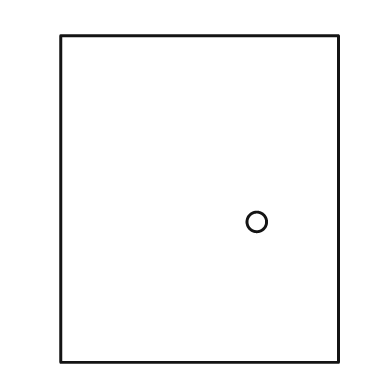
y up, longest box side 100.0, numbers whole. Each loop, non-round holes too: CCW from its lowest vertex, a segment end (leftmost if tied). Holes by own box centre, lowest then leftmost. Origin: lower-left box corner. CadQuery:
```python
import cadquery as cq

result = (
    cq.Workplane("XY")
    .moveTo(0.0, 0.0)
    .lineTo(85.0, 0.0)
    .lineTo(85.0, 100.0)
    .lineTo(0.0, 100.0)
    .close()
    .moveTo(60.0, 43.0)
    .circle(3.0)
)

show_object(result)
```